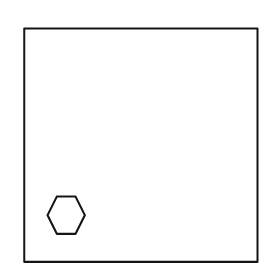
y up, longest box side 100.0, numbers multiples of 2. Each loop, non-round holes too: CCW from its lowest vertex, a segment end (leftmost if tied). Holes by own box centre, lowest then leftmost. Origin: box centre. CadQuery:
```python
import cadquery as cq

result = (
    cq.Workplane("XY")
    .moveTo(-50.0, -50.0)
    .lineTo(50.0, -50.0)
    .lineTo(50.0, 50.0)
    .lineTo(-50.0, 50.0)
    .close()
    .moveTo(-36.0, -38.0)
    .lineTo(-28.0, -38.0)
    .lineTo(-24.0, -30.0)
    .lineTo(-28.0, -22.0)
    .lineTo(-36.0, -22.0)
    .lineTo(-40.0, -30.0)
    .close()
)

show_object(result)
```